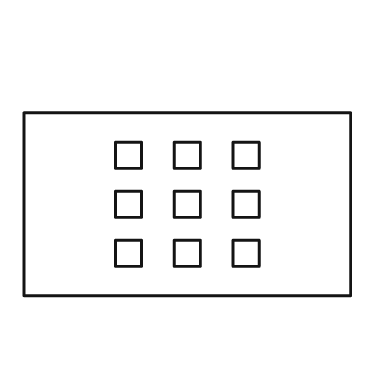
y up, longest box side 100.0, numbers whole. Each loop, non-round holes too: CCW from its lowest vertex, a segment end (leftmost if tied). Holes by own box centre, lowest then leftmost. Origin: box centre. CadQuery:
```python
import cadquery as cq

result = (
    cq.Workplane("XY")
    .moveTo(-50.0, -28.0)
    .lineTo(50.0, -28.0)
    .lineTo(50.0, 28.0)
    .lineTo(-50.0, 28.0)
    .close()
    .moveTo(-22.0, -19.0)
    .lineTo(-14.0, -19.0)
    .lineTo(-14.0, -11.0)
    .lineTo(-22.0, -11.0)
    .close()
    .moveTo(-4.0, -19.0)
    .lineTo(4.0, -19.0)
    .lineTo(4.0, -11.0)
    .lineTo(-4.0, -11.0)
    .close()
    .moveTo(14.0, -19.0)
    .lineTo(22.0, -19.0)
    .lineTo(22.0, -11.0)
    .lineTo(14.0, -11.0)
    .close()
    .moveTo(-22.0, -4.0)
    .lineTo(-14.0, -4.0)
    .lineTo(-14.0, 4.0)
    .lineTo(-22.0, 4.0)
    .close()
    .moveTo(-4.0, -4.0)
    .lineTo(4.0, -4.0)
    .lineTo(4.0, 4.0)
    .lineTo(-4.0, 4.0)
    .close()
    .moveTo(14.0, -4.0)
    .lineTo(22.0, -4.0)
    .lineTo(22.0, 4.0)
    .lineTo(14.0, 4.0)
    .close()
    .moveTo(-22.0, 11.0)
    .lineTo(-14.0, 11.0)
    .lineTo(-14.0, 19.0)
    .lineTo(-22.0, 19.0)
    .close()
    .moveTo(-4.0, 11.0)
    .lineTo(4.0, 11.0)
    .lineTo(4.0, 19.0)
    .lineTo(-4.0, 19.0)
    .close()
    .moveTo(14.0, 11.0)
    .lineTo(22.0, 11.0)
    .lineTo(22.0, 19.0)
    .lineTo(14.0, 19.0)
    .close()
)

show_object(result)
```